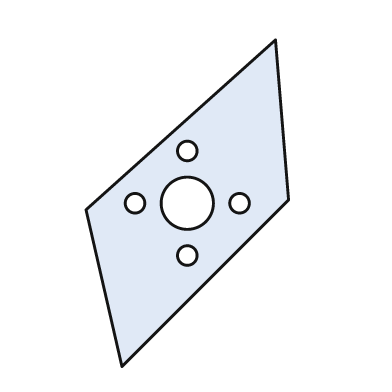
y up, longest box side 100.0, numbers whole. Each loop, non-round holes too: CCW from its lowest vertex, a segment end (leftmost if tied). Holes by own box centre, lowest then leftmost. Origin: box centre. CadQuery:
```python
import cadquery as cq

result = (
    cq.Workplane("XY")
    .moveTo(-20.0, -50.0)
    .lineTo(31.0, 1.0)
    .lineTo(27.0, 50.0)
    .lineTo(-31.0, -2.0)
    .close()
    .moveTo(0.0, -16.0)
    .circle(3.0)
    .moveTo(-16.0, 0.0)
    .circle(3.0)
    .moveTo(0.0, 0.0)
    .circle(8.0)
    .moveTo(16.0, 0.0)
    .circle(3.0)
    .moveTo(0.0, 16.0)
    .circle(3.0)
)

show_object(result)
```